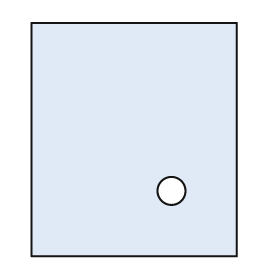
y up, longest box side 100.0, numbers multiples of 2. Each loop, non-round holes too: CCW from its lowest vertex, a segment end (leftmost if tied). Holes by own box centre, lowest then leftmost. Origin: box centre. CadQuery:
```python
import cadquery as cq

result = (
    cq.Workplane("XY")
    .moveTo(-44.0, -50.0)
    .lineTo(44.0, -50.0)
    .lineTo(44.0, 50.0)
    .lineTo(-44.0, 50.0)
    .close()
    .moveTo(16.0, -22.0)
    .circle(6.0)
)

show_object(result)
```